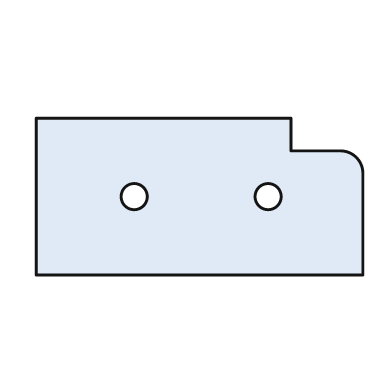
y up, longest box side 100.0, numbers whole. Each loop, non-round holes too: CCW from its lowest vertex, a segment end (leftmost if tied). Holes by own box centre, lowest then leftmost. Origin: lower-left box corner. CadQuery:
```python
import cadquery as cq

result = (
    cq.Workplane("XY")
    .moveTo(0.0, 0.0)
    .lineTo(100.0, 0.0)
    .lineTo(100.0, 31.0)
    .threePointArc((98.0, 36.0), (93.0, 38.0))
    .lineTo(78.0, 38.0)
    .lineTo(78.0, 48.0)
    .lineTo(0.0, 48.0)
    .close()
    .moveTo(30.0, 24.0)
    .circle(4.0)
    .moveTo(71.0, 24.0)
    .circle(4.0)
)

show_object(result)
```